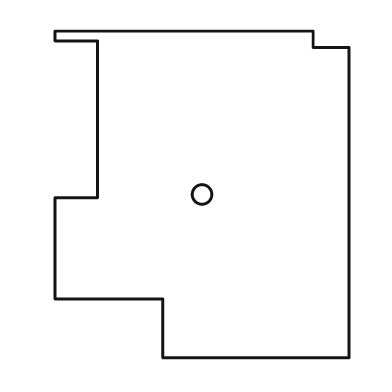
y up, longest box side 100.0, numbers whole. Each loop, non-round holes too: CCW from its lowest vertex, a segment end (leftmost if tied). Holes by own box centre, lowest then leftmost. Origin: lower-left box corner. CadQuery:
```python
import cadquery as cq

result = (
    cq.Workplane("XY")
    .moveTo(33.0, 0.0)
    .lineTo(90.0, 0.0)
    .lineTo(90.0, 95.0)
    .lineTo(79.0, 95.0)
    .lineTo(79.0, 100.0)
    .lineTo(0.0, 100.0)
    .lineTo(0.0, 97.0)
    .lineTo(13.0, 97.0)
    .lineTo(13.0, 49.0)
    .lineTo(0.0, 49.0)
    .lineTo(0.0, 18.0)
    .lineTo(33.0, 18.0)
    .close()
    .moveTo(45.0, 50.0)
    .circle(3.0)
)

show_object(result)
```